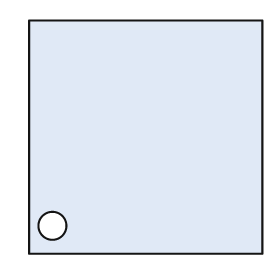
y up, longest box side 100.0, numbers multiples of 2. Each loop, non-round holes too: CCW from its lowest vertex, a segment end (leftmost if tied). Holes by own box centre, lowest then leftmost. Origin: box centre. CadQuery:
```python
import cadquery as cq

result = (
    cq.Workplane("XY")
    .moveTo(-50.0, -50.0)
    .lineTo(50.0, -50.0)
    .lineTo(50.0, 50.0)
    .lineTo(-50.0, 50.0)
    .close()
    .moveTo(-40.0, -38.0)
    .circle(6.0)
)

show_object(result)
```